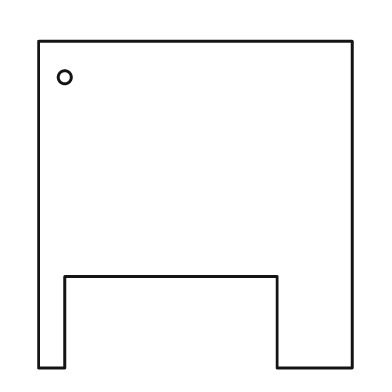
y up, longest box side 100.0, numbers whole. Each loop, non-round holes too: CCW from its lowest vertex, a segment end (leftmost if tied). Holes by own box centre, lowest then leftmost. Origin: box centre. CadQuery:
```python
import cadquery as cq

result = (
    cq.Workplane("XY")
    .moveTo(-48.0, -50.0)
    .lineTo(-40.0, -50.0)
    .lineTo(-40.0, -22.0)
    .lineTo(25.0, -22.0)
    .lineTo(25.0, -50.0)
    .lineTo(48.0, -50.0)
    .lineTo(48.0, 50.0)
    .lineTo(-48.0, 50.0)
    .close()
    .moveTo(-40.0, 39.0)
    .circle(2.0)
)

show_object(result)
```